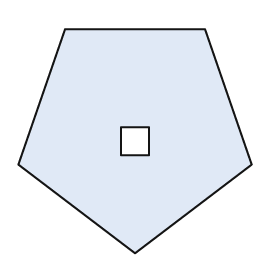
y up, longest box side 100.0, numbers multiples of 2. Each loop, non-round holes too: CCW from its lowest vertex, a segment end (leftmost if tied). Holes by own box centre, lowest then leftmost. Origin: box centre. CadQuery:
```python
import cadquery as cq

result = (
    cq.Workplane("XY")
    .moveTo(0.0, -48.0)
    .lineTo(50.0, -10.0)
    .lineTo(30.0, 48.0)
    .lineTo(-30.0, 48.0)
    .lineTo(-50.0, -10.0)
    .close()
    .moveTo(-6.0, -6.0)
    .lineTo(6.0, -6.0)
    .lineTo(6.0, 6.0)
    .lineTo(-6.0, 6.0)
    .close()
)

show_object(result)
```